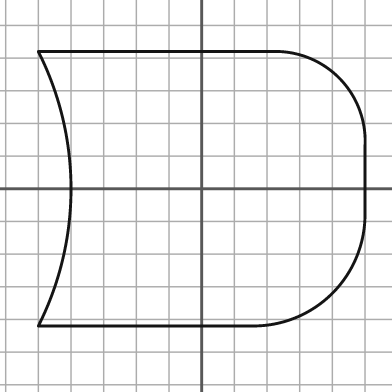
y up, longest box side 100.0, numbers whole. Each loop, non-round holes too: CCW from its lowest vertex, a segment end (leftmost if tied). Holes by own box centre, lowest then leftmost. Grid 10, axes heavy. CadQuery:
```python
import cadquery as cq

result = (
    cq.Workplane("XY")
    .moveTo(-50.0, -42.0)
    .lineTo(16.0, -42.0)
    .threePointArc((40.0, -32.0), (50.0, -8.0))
    .lineTo(50.0, 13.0)
    .threePointArc((42.0, 34.0), (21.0, 42.0))
    .lineTo(-50.0, 42.0)
    .threePointArc((-40.0, 0.0), (-50.0, -42.0))
    .close()
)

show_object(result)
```